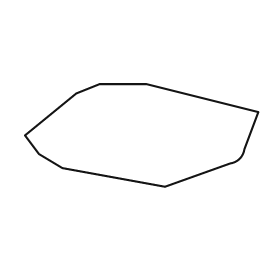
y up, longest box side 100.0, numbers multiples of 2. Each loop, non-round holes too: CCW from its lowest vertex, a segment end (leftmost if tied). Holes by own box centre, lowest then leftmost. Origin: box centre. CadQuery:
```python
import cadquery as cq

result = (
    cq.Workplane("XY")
    .moveTo(10.0, -22.0)
    .lineTo(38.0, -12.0)
    .threePointArc((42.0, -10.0), (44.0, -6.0))
    .lineTo(50.0, 10.0)
    .lineTo(2.0, 22.0)
    .lineTo(-18.0, 22.0)
    .lineTo(-28.0, 18.0)
    .lineTo(-50.0, 0.0)
    .lineTo(-44.0, -8.0)
    .lineTo(-34.0, -14.0)
    .close()
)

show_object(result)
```